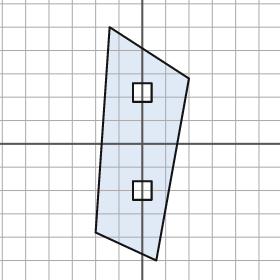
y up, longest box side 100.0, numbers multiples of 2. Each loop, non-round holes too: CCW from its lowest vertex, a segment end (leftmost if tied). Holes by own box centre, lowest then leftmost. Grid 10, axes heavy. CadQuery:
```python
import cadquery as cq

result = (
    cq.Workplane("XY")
    .moveTo(6.0, -50.0)
    .lineTo(20.0, 28.0)
    .lineTo(-14.0, 50.0)
    .lineTo(-20.0, -38.0)
    .close()
    .moveTo(-4.0, -24.0)
    .lineTo(4.0, -24.0)
    .lineTo(4.0, -16.0)
    .lineTo(-4.0, -16.0)
    .close()
    .moveTo(-4.0, 18.0)
    .lineTo(4.0, 18.0)
    .lineTo(4.0, 26.0)
    .lineTo(-4.0, 26.0)
    .close()
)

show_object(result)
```